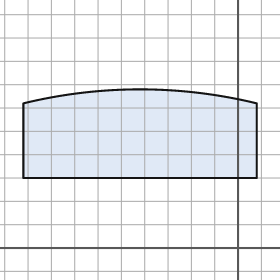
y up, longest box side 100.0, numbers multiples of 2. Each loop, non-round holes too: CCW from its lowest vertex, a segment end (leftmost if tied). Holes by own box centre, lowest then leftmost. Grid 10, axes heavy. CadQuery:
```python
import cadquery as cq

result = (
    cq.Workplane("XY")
    .moveTo(-92.0, 30.0)
    .lineTo(8.0, 30.0)
    .lineTo(8.0, 62.0)
    .threePointArc((-42.0, 68.0), (-92.0, 62.0))
    .close()
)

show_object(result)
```